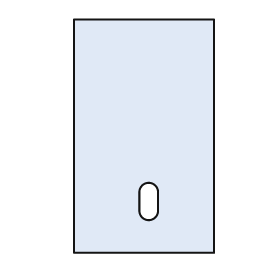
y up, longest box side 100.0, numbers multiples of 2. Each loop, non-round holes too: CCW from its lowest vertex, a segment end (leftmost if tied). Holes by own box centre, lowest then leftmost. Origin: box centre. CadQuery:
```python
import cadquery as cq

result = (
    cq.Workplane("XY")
    .moveTo(-30.0, -50.0)
    .lineTo(30.0, -50.0)
    .lineTo(30.0, 50.0)
    .lineTo(-30.0, 50.0)
    .close()
    .moveTo(-2.0, -32.0)
    .threePointArc((2.0, -36.0), (6.0, -32.0))
    .lineTo(6.0, -24.0)
    .threePointArc((2.0, -20.0), (-2.0, -24.0))
    .close()
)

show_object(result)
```